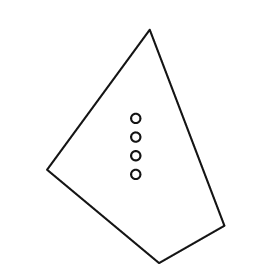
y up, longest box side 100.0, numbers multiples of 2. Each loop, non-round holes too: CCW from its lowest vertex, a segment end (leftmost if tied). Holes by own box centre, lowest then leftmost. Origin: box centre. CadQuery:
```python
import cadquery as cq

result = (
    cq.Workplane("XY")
    .moveTo(10.0, -50.0)
    .lineTo(38.0, -34.0)
    .lineTo(6.0, 50.0)
    .lineTo(-38.0, -10.0)
    .close()
    .moveTo(0.0, -12.0)
    .circle(2.0)
    .moveTo(0.0, -4.0)
    .circle(2.0)
    .moveTo(0.0, 4.0)
    .circle(2.0)
    .moveTo(0.0, 12.0)
    .circle(2.0)
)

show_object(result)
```